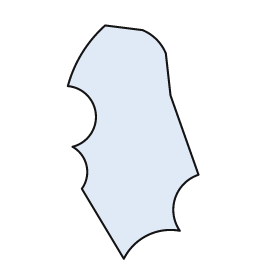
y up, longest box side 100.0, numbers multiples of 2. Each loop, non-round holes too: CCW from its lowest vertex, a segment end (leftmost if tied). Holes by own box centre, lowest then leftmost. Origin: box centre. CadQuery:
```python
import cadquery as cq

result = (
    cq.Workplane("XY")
    .moveTo(-4.0, -50.0)
    .threePointArc((6.0, -40.0), (20.0, -38.0))
    .threePointArc((18.0, -24.0), (28.0, -14.0))
    .lineTo(16.0, 20.0)
    .lineTo(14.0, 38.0)
    .threePointArc((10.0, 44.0), (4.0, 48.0))
    .lineTo(-12.0, 50.0)
    .threePointArc((-22.0, 38.0), (-28.0, 24.0))
    .threePointArc((-16.0, 12.0), (-26.0, -2.0))
    .threePointArc((-20.0, -10.0), (-22.0, -20.0))
    .close()
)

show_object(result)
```